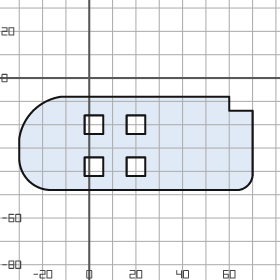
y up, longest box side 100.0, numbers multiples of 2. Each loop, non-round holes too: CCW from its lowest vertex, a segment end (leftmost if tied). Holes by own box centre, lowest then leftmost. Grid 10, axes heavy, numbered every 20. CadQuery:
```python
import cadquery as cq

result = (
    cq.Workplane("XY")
    .moveTo(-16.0, -48.0)
    .lineTo(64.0, -48.0)
    .threePointArc((68.0, -46.0), (70.0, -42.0))
    .lineTo(70.0, -14.0)
    .lineTo(60.0, -14.0)
    .lineTo(60.0, -8.0)
    .lineTo(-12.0, -8.0)
    .threePointArc((-24.0, -14.0), (-30.0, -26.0))
    .lineTo(-30.0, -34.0)
    .threePointArc((-26.0, -44.0), (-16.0, -48.0))
    .close()
    .moveTo(-2.0, -42.0)
    .lineTo(6.0, -42.0)
    .lineTo(6.0, -34.0)
    .lineTo(-2.0, -34.0)
    .close()
    .moveTo(16.0, -42.0)
    .lineTo(24.0, -42.0)
    .lineTo(24.0, -34.0)
    .lineTo(16.0, -34.0)
    .close()
    .moveTo(-2.0, -24.0)
    .lineTo(6.0, -24.0)
    .lineTo(6.0, -16.0)
    .lineTo(-2.0, -16.0)
    .close()
    .moveTo(16.0, -24.0)
    .lineTo(24.0, -24.0)
    .lineTo(24.0, -16.0)
    .lineTo(16.0, -16.0)
    .close()
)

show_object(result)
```